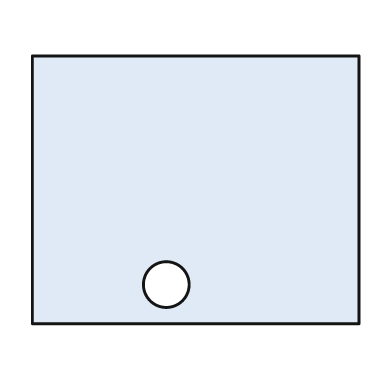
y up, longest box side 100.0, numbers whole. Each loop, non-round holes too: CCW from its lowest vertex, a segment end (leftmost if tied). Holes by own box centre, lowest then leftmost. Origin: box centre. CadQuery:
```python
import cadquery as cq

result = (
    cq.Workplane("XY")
    .moveTo(-50.0, -41.0)
    .lineTo(50.0, -41.0)
    .lineTo(50.0, 41.0)
    .lineTo(-50.0, 41.0)
    .close()
    .moveTo(-9.0, -29.0)
    .circle(7.0)
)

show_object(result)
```